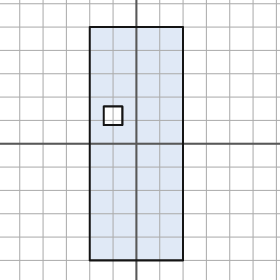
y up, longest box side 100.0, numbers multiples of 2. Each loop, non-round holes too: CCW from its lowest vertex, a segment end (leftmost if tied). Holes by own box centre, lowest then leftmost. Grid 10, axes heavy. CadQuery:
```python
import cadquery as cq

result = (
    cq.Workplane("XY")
    .moveTo(-20.0, -50.0)
    .lineTo(20.0, -50.0)
    .lineTo(20.0, 50.0)
    .lineTo(-20.0, 50.0)
    .close()
    .moveTo(-14.0, 8.0)
    .lineTo(-6.0, 8.0)
    .lineTo(-6.0, 16.0)
    .lineTo(-14.0, 16.0)
    .close()
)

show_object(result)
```